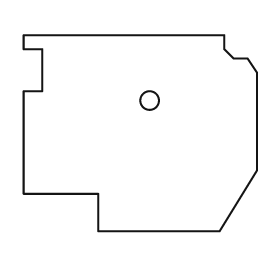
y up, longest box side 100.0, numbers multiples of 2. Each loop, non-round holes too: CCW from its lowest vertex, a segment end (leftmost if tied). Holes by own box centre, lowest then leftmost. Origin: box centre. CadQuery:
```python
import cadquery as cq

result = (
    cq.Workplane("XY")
    .moveTo(-18.0, -42.0)
    .lineTo(34.0, -42.0)
    .lineTo(50.0, -16.0)
    .lineTo(50.0, 26.0)
    .lineTo(46.0, 32.0)
    .lineTo(40.0, 32.0)
    .lineTo(36.0, 36.0)
    .lineTo(36.0, 42.0)
    .lineTo(-50.0, 42.0)
    .lineTo(-50.0, 36.0)
    .lineTo(-42.0, 36.0)
    .lineTo(-42.0, 18.0)
    .lineTo(-50.0, 18.0)
    .lineTo(-50.0, -26.0)
    .lineTo(-18.0, -26.0)
    .close()
    .moveTo(4.0, 14.0)
    .circle(4.0)
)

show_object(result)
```